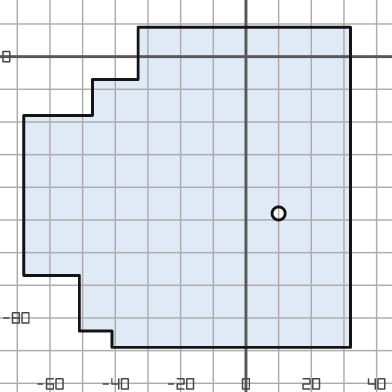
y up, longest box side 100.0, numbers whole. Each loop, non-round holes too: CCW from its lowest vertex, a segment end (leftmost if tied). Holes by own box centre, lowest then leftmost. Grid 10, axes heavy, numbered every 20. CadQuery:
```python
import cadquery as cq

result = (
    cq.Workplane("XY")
    .moveTo(-41.0, -89.0)
    .lineTo(32.0, -89.0)
    .lineTo(32.0, 9.0)
    .lineTo(-33.0, 9.0)
    .lineTo(-33.0, -7.0)
    .lineTo(-47.0, -7.0)
    .lineTo(-47.0, -18.0)
    .lineTo(-68.0, -18.0)
    .lineTo(-68.0, -67.0)
    .lineTo(-51.0, -67.0)
    .lineTo(-51.0, -84.0)
    .lineTo(-41.0, -84.0)
    .close()
    .moveTo(10.0, -48.0)
    .circle(2.0)
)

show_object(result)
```